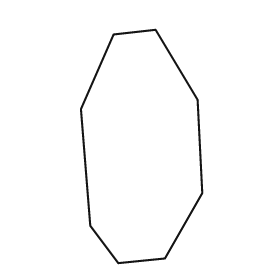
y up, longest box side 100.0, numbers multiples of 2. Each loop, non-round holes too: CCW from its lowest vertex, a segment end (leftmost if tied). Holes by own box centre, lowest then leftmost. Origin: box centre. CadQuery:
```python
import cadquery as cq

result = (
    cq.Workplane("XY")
    .moveTo(-10.0, -50.0)
    .lineTo(10.0, -48.0)
    .lineTo(26.0, -20.0)
    .lineTo(24.0, 20.0)
    .lineTo(6.0, 50.0)
    .lineTo(-12.0, 48.0)
    .lineTo(-26.0, 16.0)
    .lineTo(-22.0, -34.0)
    .close()
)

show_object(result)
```